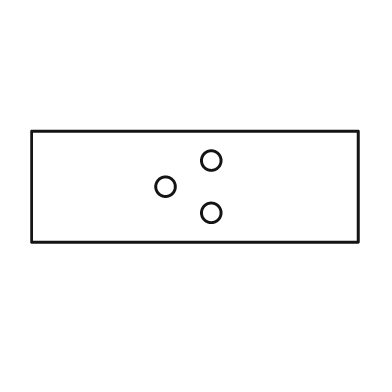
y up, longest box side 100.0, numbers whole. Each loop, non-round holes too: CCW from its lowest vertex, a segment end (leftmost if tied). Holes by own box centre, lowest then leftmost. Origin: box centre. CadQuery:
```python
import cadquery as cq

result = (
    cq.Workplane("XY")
    .moveTo(-50.0, -17.0)
    .lineTo(50.0, -17.0)
    .lineTo(50.0, 17.0)
    .lineTo(-50.0, 17.0)
    .close()
    .moveTo(5.0, -8.0)
    .circle(3.0)
    .moveTo(-9.0, 0.0)
    .circle(3.0)
    .moveTo(5.0, 8.0)
    .circle(3.0)
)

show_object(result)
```